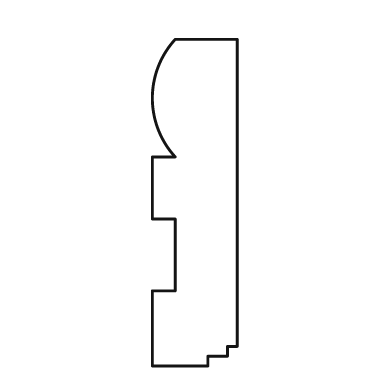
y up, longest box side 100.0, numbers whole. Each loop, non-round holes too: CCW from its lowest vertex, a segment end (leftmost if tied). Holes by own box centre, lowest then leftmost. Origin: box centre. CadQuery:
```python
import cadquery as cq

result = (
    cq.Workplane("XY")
    .moveTo(-13.0, -50.0)
    .lineTo(4.0, -50.0)
    .lineTo(4.0, -47.0)
    .lineTo(10.0, -47.0)
    .lineTo(10.0, -44.0)
    .lineTo(13.0, -44.0)
    .lineTo(13.0, 50.0)
    .lineTo(-6.0, 50.0)
    .threePointArc((-13.0, 32.0), (-6.0, 14.0))
    .lineTo(-13.0, 14.0)
    .lineTo(-13.0, -5.0)
    .lineTo(-6.0, -5.0)
    .lineTo(-6.0, -27.0)
    .lineTo(-13.0, -27.0)
    .close()
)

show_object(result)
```